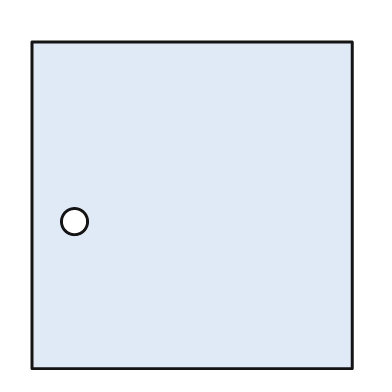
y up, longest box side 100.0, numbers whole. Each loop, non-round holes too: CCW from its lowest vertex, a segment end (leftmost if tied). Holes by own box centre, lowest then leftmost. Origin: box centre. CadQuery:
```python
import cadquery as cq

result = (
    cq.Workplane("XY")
    .moveTo(-49.0, -50.0)
    .lineTo(49.0, -50.0)
    .lineTo(49.0, 50.0)
    .lineTo(-49.0, 50.0)
    .close()
    .moveTo(-36.0, -5.0)
    .circle(4.0)
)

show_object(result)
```